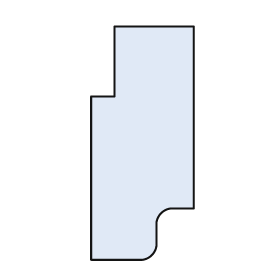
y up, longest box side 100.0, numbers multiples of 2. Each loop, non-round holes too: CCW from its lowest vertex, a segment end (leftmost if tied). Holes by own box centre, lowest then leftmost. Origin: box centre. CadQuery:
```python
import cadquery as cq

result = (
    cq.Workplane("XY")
    .moveTo(-22.0, -50.0)
    .lineTo(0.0, -50.0)
    .threePointArc((4.0, -48.0), (6.0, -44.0))
    .lineTo(6.0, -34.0)
    .threePointArc((8.0, -30.0), (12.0, -28.0))
    .lineTo(22.0, -28.0)
    .lineTo(22.0, 50.0)
    .lineTo(-12.0, 50.0)
    .lineTo(-12.0, 20.0)
    .lineTo(-22.0, 20.0)
    .close()
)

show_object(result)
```